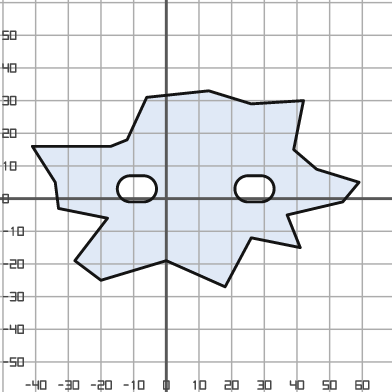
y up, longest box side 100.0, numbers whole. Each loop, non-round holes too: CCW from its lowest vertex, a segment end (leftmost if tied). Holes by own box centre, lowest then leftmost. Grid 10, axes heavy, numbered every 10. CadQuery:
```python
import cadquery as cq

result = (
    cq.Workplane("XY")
    .moveTo(18.0, -27.0)
    .lineTo(26.0, -12.0)
    .lineTo(41.0, -15.0)
    .lineTo(37.0, -5.0)
    .lineTo(54.0, -1.0)
    .lineTo(59.0, 5.0)
    .lineTo(46.0, 9.0)
    .lineTo(39.0, 15.0)
    .lineTo(42.0, 30.0)
    .lineTo(26.0, 29.0)
    .lineTo(13.0, 33.0)
    .lineTo(-6.0, 31.0)
    .lineTo(-12.0, 18.0)
    .lineTo(-17.0, 16.0)
    .lineTo(-41.0, 16.0)
    .lineTo(-34.0, 5.0)
    .lineTo(-33.0, -3.0)
    .lineTo(-18.0, -6.0)
    .lineTo(-28.0, -19.0)
    .lineTo(-20.0, -25.0)
    .lineTo(0.0, -19.0)
    .close()
    .moveTo(-11.0, -1.0)
    .lineTo(-7.0, -1.0)
    .threePointArc((-3.0, 3.0), (-7.0, 7.0))
    .lineTo(-11.0, 7.0)
    .threePointArc((-15.0, 3.0), (-11.0, -1.0))
    .close()
    .moveTo(25.0, -1.0)
    .lineTo(29.0, -1.0)
    .threePointArc((33.0, 3.0), (29.0, 7.0))
    .lineTo(25.0, 7.0)
    .threePointArc((21.0, 3.0), (25.0, -1.0))
    .close()
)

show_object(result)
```